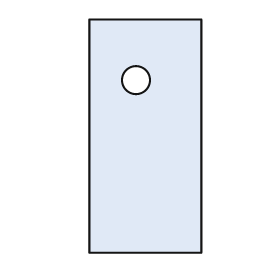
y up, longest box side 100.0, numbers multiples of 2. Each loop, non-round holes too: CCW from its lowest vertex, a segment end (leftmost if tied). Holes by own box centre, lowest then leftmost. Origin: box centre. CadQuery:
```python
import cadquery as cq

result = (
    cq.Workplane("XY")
    .moveTo(-24.0, -50.0)
    .lineTo(24.0, -50.0)
    .lineTo(24.0, 50.0)
    .lineTo(-24.0, 50.0)
    .close()
    .moveTo(-4.0, 24.0)
    .circle(6.0)
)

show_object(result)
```